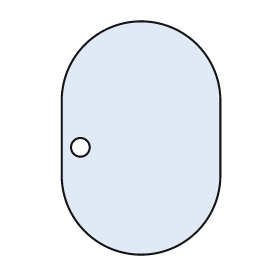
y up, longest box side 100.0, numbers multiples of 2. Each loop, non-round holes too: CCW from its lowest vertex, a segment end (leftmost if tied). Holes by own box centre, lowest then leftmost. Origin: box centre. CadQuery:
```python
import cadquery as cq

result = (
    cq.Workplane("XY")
    .moveTo(-34.0, -16.0)
    .threePointArc((0.0, -50.0), (34.0, -16.0))
    .lineTo(34.0, 16.0)
    .threePointArc((0.0, 50.0), (-34.0, 16.0))
    .close()
    .moveTo(-26.0, -4.0)
    .circle(4.0)
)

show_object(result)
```